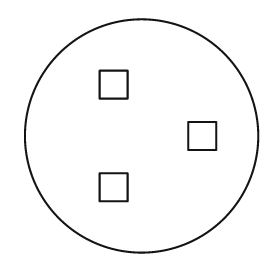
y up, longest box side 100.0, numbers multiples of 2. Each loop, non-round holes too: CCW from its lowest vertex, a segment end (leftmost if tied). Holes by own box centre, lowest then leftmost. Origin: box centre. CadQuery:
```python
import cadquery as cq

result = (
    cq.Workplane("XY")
    .moveTo(0.0, 0.0)
    .circle(50.0)
    .moveTo(-18.0, -28.0)
    .lineTo(-6.0, -28.0)
    .lineTo(-6.0, -16.0)
    .lineTo(-18.0, -16.0)
    .close()
    .moveTo(20.0, -6.0)
    .lineTo(32.0, -6.0)
    .lineTo(32.0, 6.0)
    .lineTo(20.0, 6.0)
    .close()
    .moveTo(-18.0, 16.0)
    .lineTo(-6.0, 16.0)
    .lineTo(-6.0, 28.0)
    .lineTo(-18.0, 28.0)
    .close()
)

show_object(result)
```